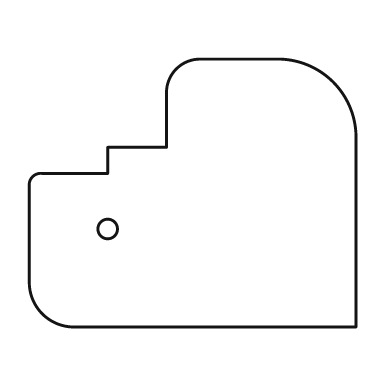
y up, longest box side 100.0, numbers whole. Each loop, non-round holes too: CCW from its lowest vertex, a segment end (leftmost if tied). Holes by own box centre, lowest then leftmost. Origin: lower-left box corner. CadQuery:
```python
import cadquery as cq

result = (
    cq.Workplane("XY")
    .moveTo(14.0, 0.0)
    .lineTo(100.0, 0.0)
    .lineTo(100.0, 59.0)
    .threePointArc((93.0, 75.0), (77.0, 82.0))
    .lineTo(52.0, 82.0)
    .threePointArc((45.0, 79.0), (42.0, 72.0))
    .lineTo(42.0, 55.0)
    .lineTo(24.0, 55.0)
    .lineTo(24.0, 47.0)
    .lineTo(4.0, 47.0)
    .threePointArc((1.0, 46.0), (0.0, 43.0))
    .lineTo(0.0, 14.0)
    .threePointArc((4.0, 4.0), (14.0, 0.0))
    .close()
    .moveTo(24.0, 30.0)
    .circle(3.0)
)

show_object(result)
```